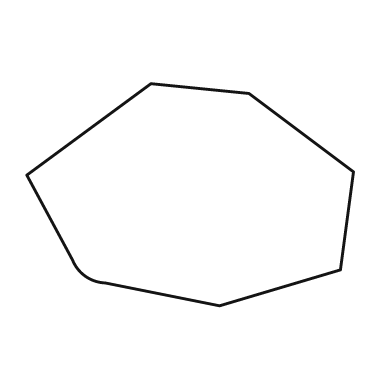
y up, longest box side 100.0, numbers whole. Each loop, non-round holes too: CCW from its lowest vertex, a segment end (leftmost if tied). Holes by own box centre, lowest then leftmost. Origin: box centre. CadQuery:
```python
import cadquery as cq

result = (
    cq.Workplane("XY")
    .moveTo(9.0, -34.0)
    .lineTo(46.0, -23.0)
    .lineTo(50.0, 7.0)
    .lineTo(18.0, 31.0)
    .lineTo(-12.0, 34.0)
    .lineTo(-50.0, 6.0)
    .lineTo(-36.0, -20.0)
    .threePointArc((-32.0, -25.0), (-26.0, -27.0))
    .close()
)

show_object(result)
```